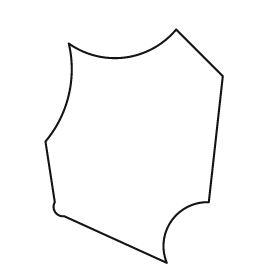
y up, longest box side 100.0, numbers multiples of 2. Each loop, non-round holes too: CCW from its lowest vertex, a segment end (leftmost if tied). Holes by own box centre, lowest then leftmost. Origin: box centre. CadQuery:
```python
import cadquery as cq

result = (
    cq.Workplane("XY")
    .moveTo(14.0, -50.0)
    .threePointArc((16.0, -32.0), (32.0, -24.0))
    .lineTo(38.0, 30.0)
    .lineTo(18.0, 50.0)
    .threePointArc((-4.0, 38.0), (-28.0, 44.0))
    .threePointArc((-28.0, 22.0), (-38.0, 2.0))
    .lineTo(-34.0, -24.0)
    .threePointArc((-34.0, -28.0), (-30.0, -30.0))
    .close()
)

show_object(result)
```